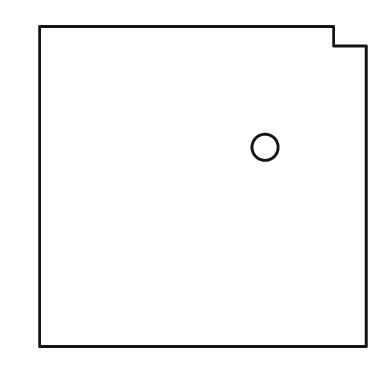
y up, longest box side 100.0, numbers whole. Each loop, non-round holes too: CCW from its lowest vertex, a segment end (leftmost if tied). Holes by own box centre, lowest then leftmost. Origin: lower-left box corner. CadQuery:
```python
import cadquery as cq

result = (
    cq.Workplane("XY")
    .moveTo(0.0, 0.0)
    .lineTo(100.0, 0.0)
    .lineTo(100.0, 92.0)
    .lineTo(90.0, 92.0)
    .lineTo(90.0, 98.0)
    .lineTo(0.0, 98.0)
    .close()
    .moveTo(69.0, 61.0)
    .circle(4.0)
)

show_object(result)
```